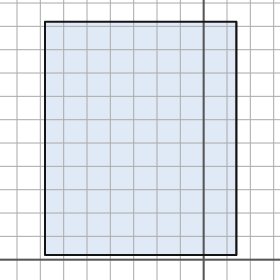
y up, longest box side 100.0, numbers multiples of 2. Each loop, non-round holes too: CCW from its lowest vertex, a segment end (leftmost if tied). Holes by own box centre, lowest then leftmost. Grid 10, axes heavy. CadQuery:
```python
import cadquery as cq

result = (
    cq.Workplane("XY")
    .moveTo(-68.0, 2.0)
    .lineTo(14.0, 2.0)
    .lineTo(14.0, 102.0)
    .lineTo(-68.0, 102.0)
    .close()
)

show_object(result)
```